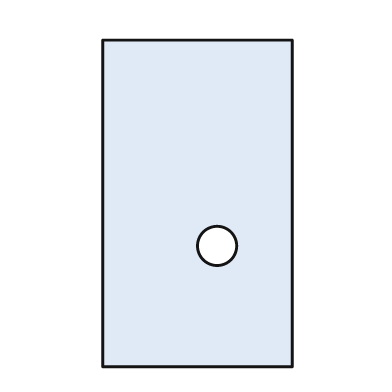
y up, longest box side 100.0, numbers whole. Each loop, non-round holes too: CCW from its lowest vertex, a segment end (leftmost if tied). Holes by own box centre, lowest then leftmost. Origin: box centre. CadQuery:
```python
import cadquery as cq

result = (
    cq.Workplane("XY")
    .moveTo(-29.0, -50.0)
    .lineTo(29.0, -50.0)
    .lineTo(29.0, 50.0)
    .lineTo(-29.0, 50.0)
    .close()
    .moveTo(6.0, -13.0)
    .circle(6.0)
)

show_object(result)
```